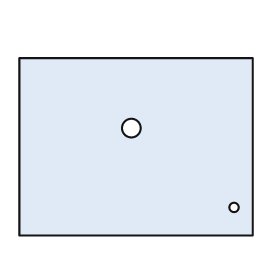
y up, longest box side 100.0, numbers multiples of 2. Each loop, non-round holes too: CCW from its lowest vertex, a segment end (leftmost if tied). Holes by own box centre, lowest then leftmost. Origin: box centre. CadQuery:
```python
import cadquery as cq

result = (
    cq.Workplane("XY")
    .moveTo(-50.0, -38.0)
    .lineTo(50.0, -38.0)
    .lineTo(50.0, 38.0)
    .lineTo(-50.0, 38.0)
    .close()
    .moveTo(42.0, -26.0)
    .circle(2.0)
    .moveTo(-2.0, 8.0)
    .circle(4.0)
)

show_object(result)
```